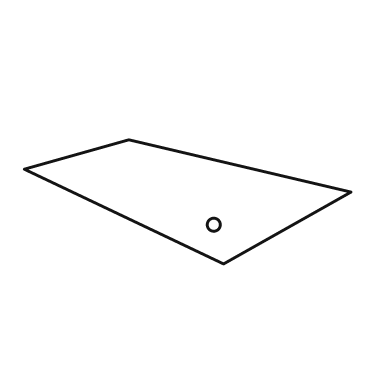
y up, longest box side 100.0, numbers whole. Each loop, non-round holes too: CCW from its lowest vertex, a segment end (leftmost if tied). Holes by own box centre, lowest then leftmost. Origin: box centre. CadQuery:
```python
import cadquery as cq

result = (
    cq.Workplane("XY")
    .moveTo(11.0, -19.0)
    .lineTo(50.0, 3.0)
    .lineTo(-18.0, 19.0)
    .lineTo(-50.0, 10.0)
    .close()
    .moveTo(8.0, -7.0)
    .circle(2.0)
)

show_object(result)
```